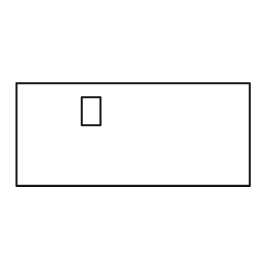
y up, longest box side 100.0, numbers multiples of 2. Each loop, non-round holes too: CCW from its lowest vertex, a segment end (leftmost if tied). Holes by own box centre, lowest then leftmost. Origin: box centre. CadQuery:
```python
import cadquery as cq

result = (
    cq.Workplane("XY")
    .moveTo(-50.0, -22.0)
    .lineTo(50.0, -22.0)
    .lineTo(50.0, 22.0)
    .lineTo(-50.0, 22.0)
    .close()
    .moveTo(-22.0, 4.0)
    .lineTo(-14.0, 4.0)
    .lineTo(-14.0, 16.0)
    .lineTo(-22.0, 16.0)
    .close()
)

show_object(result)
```